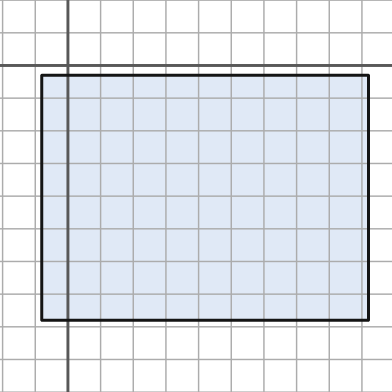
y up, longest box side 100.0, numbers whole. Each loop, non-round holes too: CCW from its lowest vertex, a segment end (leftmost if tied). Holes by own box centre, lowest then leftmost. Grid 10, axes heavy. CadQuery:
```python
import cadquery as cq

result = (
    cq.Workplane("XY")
    .moveTo(-8.0, -78.0)
    .lineTo(92.0, -78.0)
    .lineTo(92.0, -3.0)
    .lineTo(-8.0, -3.0)
    .close()
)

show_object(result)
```